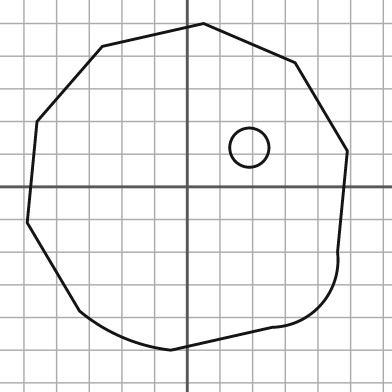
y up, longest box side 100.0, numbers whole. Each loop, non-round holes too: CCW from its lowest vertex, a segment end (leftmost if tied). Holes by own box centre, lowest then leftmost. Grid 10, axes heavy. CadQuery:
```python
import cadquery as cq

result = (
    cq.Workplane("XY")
    .moveTo(-5.0, -50.0)
    .lineTo(26.0, -43.0)
    .threePointArc((41.0, -36.0), (46.0, -20.0))
    .lineTo(49.0, 11.0)
    .lineTo(33.0, 38.0)
    .lineTo(5.0, 50.0)
    .lineTo(-26.0, 43.0)
    .lineTo(-46.0, 20.0)
    .lineTo(-49.0, -11.0)
    .lineTo(-33.0, -38.0)
    .threePointArc((-20.0, -46.0), (-5.0, -50.0))
    .close()
    .moveTo(19.0, 12.0)
    .circle(6.0)
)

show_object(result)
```